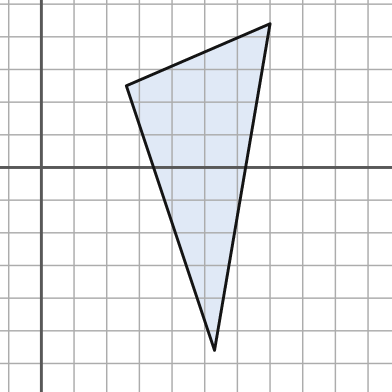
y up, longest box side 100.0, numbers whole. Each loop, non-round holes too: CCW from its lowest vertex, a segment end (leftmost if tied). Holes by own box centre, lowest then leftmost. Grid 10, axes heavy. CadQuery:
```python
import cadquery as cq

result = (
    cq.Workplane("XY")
    .moveTo(53.0, -56.0)
    .lineTo(70.0, 44.0)
    .lineTo(26.0, 25.0)
    .close()
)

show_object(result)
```